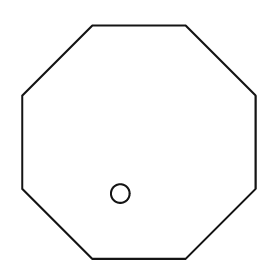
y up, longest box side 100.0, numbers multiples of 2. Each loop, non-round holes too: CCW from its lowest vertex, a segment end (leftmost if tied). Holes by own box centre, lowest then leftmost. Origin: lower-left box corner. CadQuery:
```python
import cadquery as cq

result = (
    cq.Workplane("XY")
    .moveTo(30.0, 0.0)
    .lineTo(70.0, 0.0)
    .lineTo(100.0, 30.0)
    .lineTo(100.0, 70.0)
    .lineTo(70.0, 100.0)
    .lineTo(30.0, 100.0)
    .lineTo(0.0, 70.0)
    .lineTo(0.0, 30.0)
    .close()
    .moveTo(42.0, 28.0)
    .circle(4.0)
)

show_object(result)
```